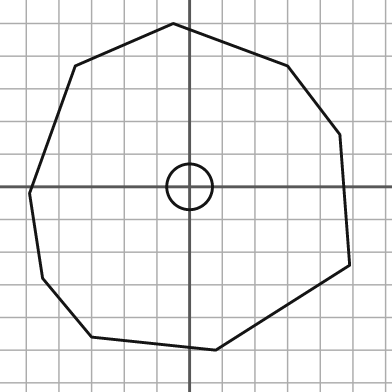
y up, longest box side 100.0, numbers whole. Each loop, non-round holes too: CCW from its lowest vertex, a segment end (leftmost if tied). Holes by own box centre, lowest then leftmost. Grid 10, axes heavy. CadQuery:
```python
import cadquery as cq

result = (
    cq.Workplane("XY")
    .moveTo(8.0, -50.0)
    .lineTo(49.0, -24.0)
    .lineTo(46.0, 16.0)
    .lineTo(30.0, 37.0)
    .lineTo(-5.0, 50.0)
    .lineTo(-35.0, 37.0)
    .lineTo(-49.0, -2.0)
    .lineTo(-45.0, -28.0)
    .lineTo(-30.0, -46.0)
    .close()
    .moveTo(0.0, 0.0)
    .circle(7.0)
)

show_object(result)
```